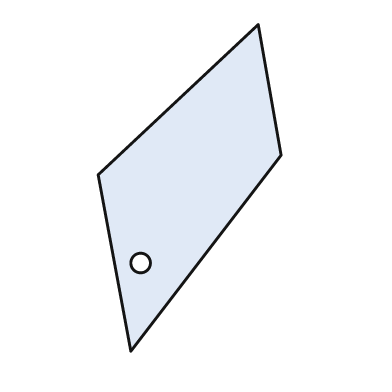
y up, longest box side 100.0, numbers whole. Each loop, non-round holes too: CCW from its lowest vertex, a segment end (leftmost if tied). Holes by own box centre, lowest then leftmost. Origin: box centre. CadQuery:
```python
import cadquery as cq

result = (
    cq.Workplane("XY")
    .moveTo(-18.0, -50.0)
    .lineTo(28.0, 10.0)
    .lineTo(21.0, 50.0)
    .lineTo(-28.0, 4.0)
    .close()
    .moveTo(-15.0, -23.0)
    .circle(3.0)
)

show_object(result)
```